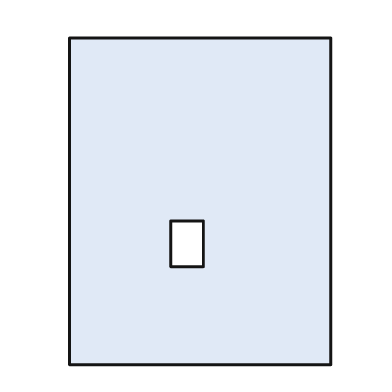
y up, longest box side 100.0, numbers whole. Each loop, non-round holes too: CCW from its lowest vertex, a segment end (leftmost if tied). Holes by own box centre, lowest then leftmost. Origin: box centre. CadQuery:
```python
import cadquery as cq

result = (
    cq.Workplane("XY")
    .moveTo(-40.0, -50.0)
    .lineTo(40.0, -50.0)
    .lineTo(40.0, 50.0)
    .lineTo(-40.0, 50.0)
    .close()
    .moveTo(-9.0, -20.0)
    .lineTo(1.0, -20.0)
    .lineTo(1.0, -6.0)
    .lineTo(-9.0, -6.0)
    .close()
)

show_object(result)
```